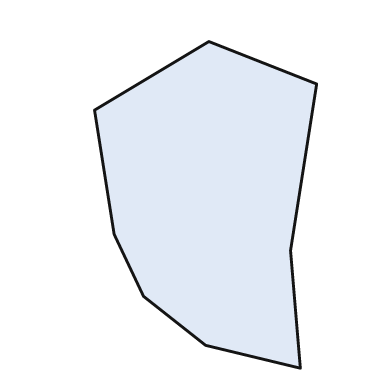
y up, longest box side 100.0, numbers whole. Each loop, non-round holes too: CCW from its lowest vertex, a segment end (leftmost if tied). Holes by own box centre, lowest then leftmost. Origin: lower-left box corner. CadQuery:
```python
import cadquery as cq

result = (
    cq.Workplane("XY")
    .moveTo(63.0, 0.0)
    .lineTo(60.0, 36.0)
    .lineTo(68.0, 87.0)
    .lineTo(35.0, 100.0)
    .lineTo(0.0, 79.0)
    .lineTo(6.0, 41.0)
    .lineTo(15.0, 22.0)
    .lineTo(34.0, 7.0)
    .close()
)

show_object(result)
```